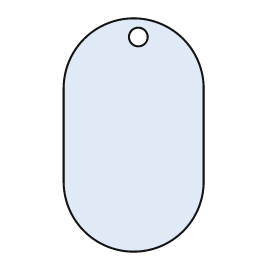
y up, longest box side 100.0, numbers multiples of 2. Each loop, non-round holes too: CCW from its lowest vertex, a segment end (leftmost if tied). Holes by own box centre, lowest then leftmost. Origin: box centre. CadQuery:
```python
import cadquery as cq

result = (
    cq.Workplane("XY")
    .moveTo(-30.0, -20.0)
    .threePointArc((0.0, -50.0), (30.0, -20.0))
    .lineTo(30.0, 20.0)
    .threePointArc((0.0, 50.0), (-30.0, 20.0))
    .close()
    .moveTo(2.0, 42.0)
    .circle(4.0)
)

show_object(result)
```